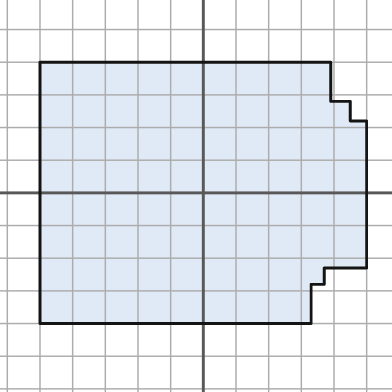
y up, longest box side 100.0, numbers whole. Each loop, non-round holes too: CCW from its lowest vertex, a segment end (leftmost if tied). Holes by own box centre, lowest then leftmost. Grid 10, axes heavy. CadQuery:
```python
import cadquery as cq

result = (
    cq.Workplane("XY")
    .moveTo(-50.0, -40.0)
    .lineTo(33.0, -40.0)
    .lineTo(33.0, -28.0)
    .lineTo(37.0, -28.0)
    .lineTo(37.0, -23.0)
    .lineTo(50.0, -23.0)
    .lineTo(50.0, 22.0)
    .lineTo(45.0, 22.0)
    .lineTo(45.0, 28.0)
    .lineTo(39.0, 28.0)
    .lineTo(39.0, 40.0)
    .lineTo(-50.0, 40.0)
    .close()
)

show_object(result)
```